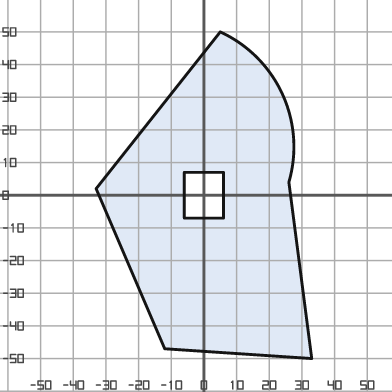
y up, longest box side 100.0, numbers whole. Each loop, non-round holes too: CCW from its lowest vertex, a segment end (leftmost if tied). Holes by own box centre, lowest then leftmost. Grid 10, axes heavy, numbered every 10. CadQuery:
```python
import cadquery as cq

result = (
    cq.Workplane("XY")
    .moveTo(33.0, -50.0)
    .lineTo(26.0, 4.0)
    .threePointArc((24.0, 31.0), (5.0, 50.0))
    .lineTo(-33.0, 2.0)
    .lineTo(-12.0, -47.0)
    .close()
    .moveTo(-6.0, -7.0)
    .lineTo(6.0, -7.0)
    .lineTo(6.0, 7.0)
    .lineTo(-6.0, 7.0)
    .close()
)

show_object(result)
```